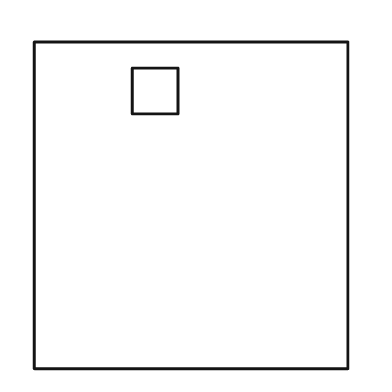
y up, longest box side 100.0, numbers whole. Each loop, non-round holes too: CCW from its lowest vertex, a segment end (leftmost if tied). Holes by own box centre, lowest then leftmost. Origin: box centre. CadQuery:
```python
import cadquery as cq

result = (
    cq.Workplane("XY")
    .moveTo(-48.0, -50.0)
    .lineTo(48.0, -50.0)
    .lineTo(48.0, 50.0)
    .lineTo(-48.0, 50.0)
    .close()
    .moveTo(-18.0, 28.0)
    .lineTo(-4.0, 28.0)
    .lineTo(-4.0, 42.0)
    .lineTo(-18.0, 42.0)
    .close()
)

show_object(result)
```